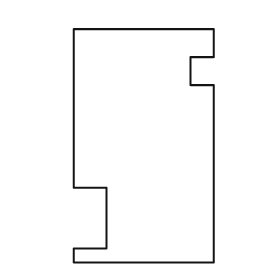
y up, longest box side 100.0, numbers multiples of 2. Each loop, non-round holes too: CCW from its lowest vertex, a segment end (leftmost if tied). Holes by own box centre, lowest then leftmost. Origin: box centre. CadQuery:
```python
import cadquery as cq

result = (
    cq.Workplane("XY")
    .moveTo(-30.0, -50.0)
    .lineTo(30.0, -50.0)
    .lineTo(30.0, 26.0)
    .lineTo(20.0, 26.0)
    .lineTo(20.0, 38.0)
    .lineTo(30.0, 38.0)
    .lineTo(30.0, 50.0)
    .lineTo(-30.0, 50.0)
    .lineTo(-30.0, -18.0)
    .lineTo(-16.0, -18.0)
    .lineTo(-16.0, -44.0)
    .lineTo(-30.0, -44.0)
    .close()
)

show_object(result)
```